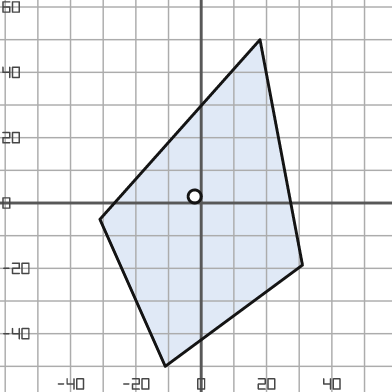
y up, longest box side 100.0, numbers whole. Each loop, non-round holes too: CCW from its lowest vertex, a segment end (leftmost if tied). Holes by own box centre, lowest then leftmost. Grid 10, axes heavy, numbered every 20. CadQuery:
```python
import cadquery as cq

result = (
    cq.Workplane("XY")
    .moveTo(-11.0, -50.0)
    .lineTo(31.0, -19.0)
    .lineTo(18.0, 50.0)
    .lineTo(-31.0, -5.0)
    .close()
    .moveTo(-2.0, 2.0)
    .circle(2.0)
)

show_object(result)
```